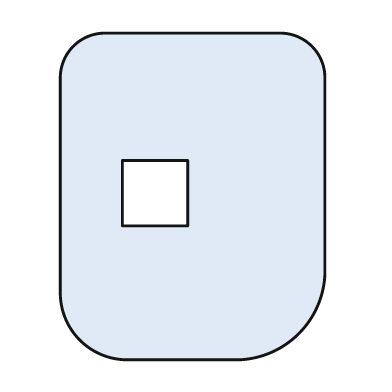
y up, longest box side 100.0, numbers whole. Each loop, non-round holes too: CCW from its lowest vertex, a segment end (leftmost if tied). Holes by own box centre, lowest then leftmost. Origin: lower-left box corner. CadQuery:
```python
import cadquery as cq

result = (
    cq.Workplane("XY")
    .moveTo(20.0, 0.0)
    .lineTo(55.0, 0.0)
    .threePointArc((73.0, 8.0), (81.0, 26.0))
    .lineTo(81.0, 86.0)
    .threePointArc((77.0, 96.0), (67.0, 100.0))
    .lineTo(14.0, 100.0)
    .threePointArc((4.0, 96.0), (0.0, 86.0))
    .lineTo(0.0, 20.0)
    .threePointArc((6.0, 6.0), (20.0, 0.0))
    .close()
    .moveTo(19.0, 41.0)
    .lineTo(39.0, 41.0)
    .lineTo(39.0, 61.0)
    .lineTo(19.0, 61.0)
    .close()
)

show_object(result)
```